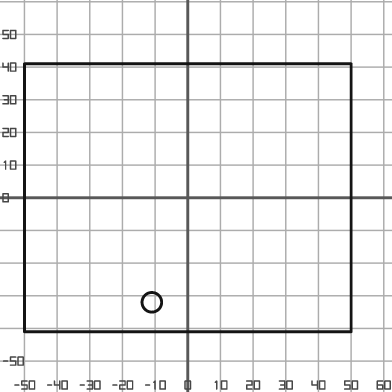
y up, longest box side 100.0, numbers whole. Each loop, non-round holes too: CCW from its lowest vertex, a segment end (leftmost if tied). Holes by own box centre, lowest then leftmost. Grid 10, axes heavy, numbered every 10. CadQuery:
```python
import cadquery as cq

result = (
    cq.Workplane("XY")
    .moveTo(-50.0, -41.0)
    .lineTo(50.0, -41.0)
    .lineTo(50.0, 41.0)
    .lineTo(-50.0, 41.0)
    .close()
    .moveTo(-11.0, -32.0)
    .circle(3.0)
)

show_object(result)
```